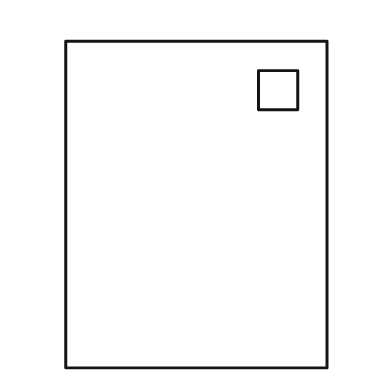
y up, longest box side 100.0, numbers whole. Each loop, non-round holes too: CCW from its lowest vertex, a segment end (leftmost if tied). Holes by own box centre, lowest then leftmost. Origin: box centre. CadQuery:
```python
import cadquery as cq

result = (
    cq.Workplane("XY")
    .moveTo(-40.0, -50.0)
    .lineTo(40.0, -50.0)
    .lineTo(40.0, 50.0)
    .lineTo(-40.0, 50.0)
    .close()
    .moveTo(19.0, 29.0)
    .lineTo(31.0, 29.0)
    .lineTo(31.0, 41.0)
    .lineTo(19.0, 41.0)
    .close()
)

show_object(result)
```